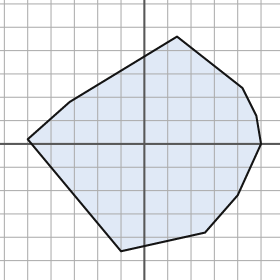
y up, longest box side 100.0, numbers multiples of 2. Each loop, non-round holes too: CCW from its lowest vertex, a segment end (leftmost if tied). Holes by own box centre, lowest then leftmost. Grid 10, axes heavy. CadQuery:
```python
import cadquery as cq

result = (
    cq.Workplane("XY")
    .moveTo(-10.0, -46.0)
    .lineTo(26.0, -38.0)
    .lineTo(40.0, -22.0)
    .lineTo(50.0, 0.0)
    .lineTo(48.0, 12.0)
    .lineTo(42.0, 24.0)
    .lineTo(14.0, 46.0)
    .lineTo(-32.0, 18.0)
    .lineTo(-50.0, 2.0)
    .close()
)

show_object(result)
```